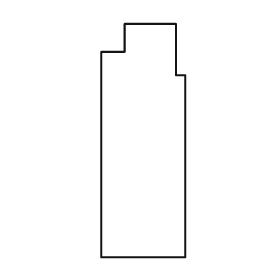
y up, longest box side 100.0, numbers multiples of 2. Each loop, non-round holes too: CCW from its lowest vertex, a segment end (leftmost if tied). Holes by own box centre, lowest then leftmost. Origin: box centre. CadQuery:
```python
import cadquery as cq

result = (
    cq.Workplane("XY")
    .moveTo(-18.0, -50.0)
    .lineTo(18.0, -50.0)
    .lineTo(18.0, 28.0)
    .lineTo(14.0, 28.0)
    .lineTo(14.0, 50.0)
    .lineTo(-8.0, 50.0)
    .lineTo(-8.0, 38.0)
    .lineTo(-18.0, 38.0)
    .close()
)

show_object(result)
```